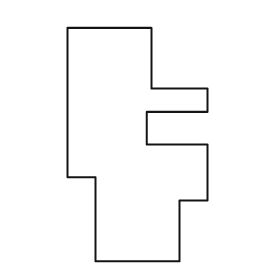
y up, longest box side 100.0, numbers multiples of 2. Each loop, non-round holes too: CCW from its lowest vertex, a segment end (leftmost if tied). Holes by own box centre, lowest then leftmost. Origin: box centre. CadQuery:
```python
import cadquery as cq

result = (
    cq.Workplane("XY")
    .moveTo(-18.0, -50.0)
    .lineTo(18.0, -50.0)
    .lineTo(18.0, -24.0)
    .lineTo(30.0, -24.0)
    .lineTo(30.0, 0.0)
    .lineTo(4.0, 0.0)
    .lineTo(4.0, 14.0)
    .lineTo(30.0, 14.0)
    .lineTo(30.0, 24.0)
    .lineTo(6.0, 24.0)
    .lineTo(6.0, 50.0)
    .lineTo(-30.0, 50.0)
    .lineTo(-30.0, -14.0)
    .lineTo(-18.0, -14.0)
    .close()
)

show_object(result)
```